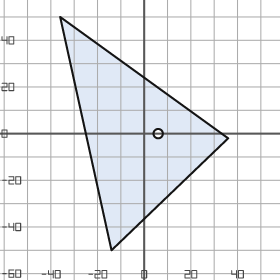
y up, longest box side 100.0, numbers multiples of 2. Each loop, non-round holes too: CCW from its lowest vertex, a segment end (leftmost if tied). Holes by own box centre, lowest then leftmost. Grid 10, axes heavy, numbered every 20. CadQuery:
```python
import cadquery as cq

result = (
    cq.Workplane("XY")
    .moveTo(-14.0, -50.0)
    .lineTo(36.0, -2.0)
    .lineTo(-36.0, 50.0)
    .close()
    .moveTo(6.0, 0.0)
    .circle(2.0)
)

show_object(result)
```